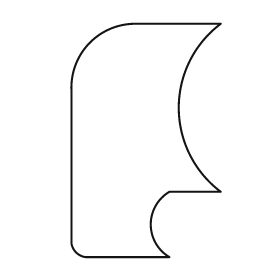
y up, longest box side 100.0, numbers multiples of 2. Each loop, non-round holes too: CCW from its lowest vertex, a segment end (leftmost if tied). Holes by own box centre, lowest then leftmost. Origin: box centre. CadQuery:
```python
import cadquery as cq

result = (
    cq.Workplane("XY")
    .moveTo(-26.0, -50.0)
    .lineTo(10.0, -50.0)
    .threePointArc((2.0, -36.0), (10.0, -22.0))
    .lineTo(32.0, -22.0)
    .threePointArc((14.0, 14.0), (32.0, 50.0))
    .lineTo(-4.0, 50.0)
    .threePointArc((-24.0, 42.0), (-32.0, 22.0))
    .lineTo(-32.0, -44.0)
    .threePointArc((-30.0, -48.0), (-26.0, -50.0))
    .close()
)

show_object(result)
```